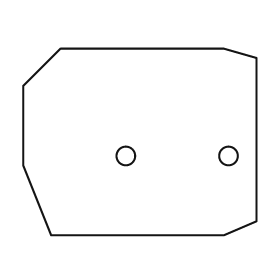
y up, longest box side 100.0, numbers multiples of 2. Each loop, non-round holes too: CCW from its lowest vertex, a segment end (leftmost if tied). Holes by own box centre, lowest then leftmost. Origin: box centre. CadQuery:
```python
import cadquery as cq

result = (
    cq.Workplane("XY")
    .moveTo(-38.0, -40.0)
    .lineTo(36.0, -40.0)
    .lineTo(50.0, -34.0)
    .lineTo(50.0, 36.0)
    .lineTo(36.0, 40.0)
    .lineTo(-34.0, 40.0)
    .lineTo(-50.0, 24.0)
    .lineTo(-50.0, -10.0)
    .close()
    .moveTo(-6.0, -6.0)
    .circle(4.0)
    .moveTo(38.0, -6.0)
    .circle(4.0)
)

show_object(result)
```